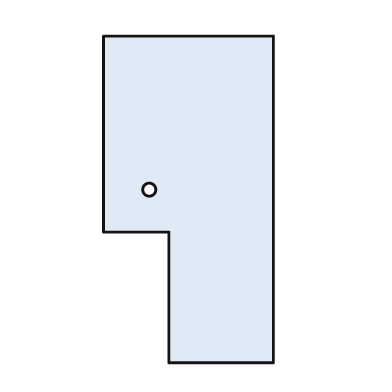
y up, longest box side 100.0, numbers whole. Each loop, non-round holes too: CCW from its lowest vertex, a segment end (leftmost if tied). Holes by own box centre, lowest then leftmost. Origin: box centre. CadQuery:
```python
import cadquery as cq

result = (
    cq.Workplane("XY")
    .moveTo(-6.0, -50.0)
    .lineTo(26.0, -50.0)
    .lineTo(26.0, 50.0)
    .lineTo(-26.0, 50.0)
    .lineTo(-26.0, -10.0)
    .lineTo(-6.0, -10.0)
    .close()
    .moveTo(-12.0, 3.0)
    .circle(2.0)
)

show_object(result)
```